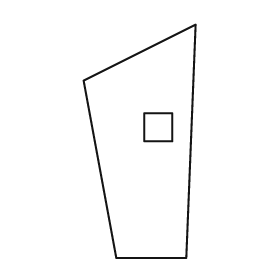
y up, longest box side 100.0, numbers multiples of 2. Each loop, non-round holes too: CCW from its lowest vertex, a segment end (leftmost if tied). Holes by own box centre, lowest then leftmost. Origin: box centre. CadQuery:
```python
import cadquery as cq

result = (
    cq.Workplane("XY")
    .moveTo(-10.0, -50.0)
    .lineTo(20.0, -50.0)
    .lineTo(24.0, 50.0)
    .lineTo(-24.0, 26.0)
    .close()
    .moveTo(2.0, 0.0)
    .lineTo(14.0, 0.0)
    .lineTo(14.0, 12.0)
    .lineTo(2.0, 12.0)
    .close()
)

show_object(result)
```